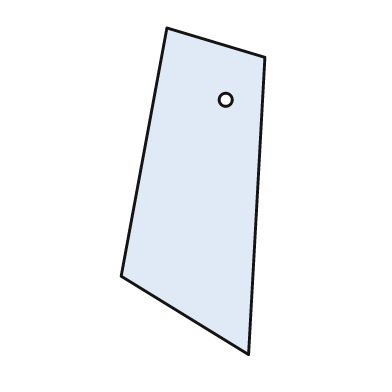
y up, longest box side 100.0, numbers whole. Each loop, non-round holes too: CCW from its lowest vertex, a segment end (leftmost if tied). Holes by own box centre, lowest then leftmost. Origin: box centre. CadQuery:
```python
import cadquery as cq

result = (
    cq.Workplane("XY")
    .moveTo(17.0, -50.0)
    .lineTo(22.0, 41.0)
    .lineTo(-8.0, 50.0)
    .lineTo(-22.0, -26.0)
    .close()
    .moveTo(10.0, 28.0)
    .circle(2.0)
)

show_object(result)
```